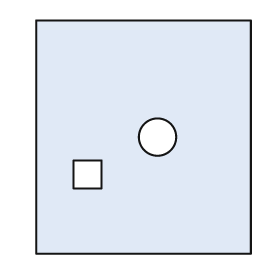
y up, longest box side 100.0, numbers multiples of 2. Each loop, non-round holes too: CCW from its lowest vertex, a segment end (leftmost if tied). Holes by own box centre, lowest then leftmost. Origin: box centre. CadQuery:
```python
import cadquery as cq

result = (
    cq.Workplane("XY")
    .moveTo(-46.0, -50.0)
    .lineTo(46.0, -50.0)
    .lineTo(46.0, 50.0)
    .lineTo(-46.0, 50.0)
    .close()
    .moveTo(-30.0, -22.0)
    .lineTo(-18.0, -22.0)
    .lineTo(-18.0, -10.0)
    .lineTo(-30.0, -10.0)
    .close()
    .moveTo(6.0, 0.0)
    .circle(8.0)
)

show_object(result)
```